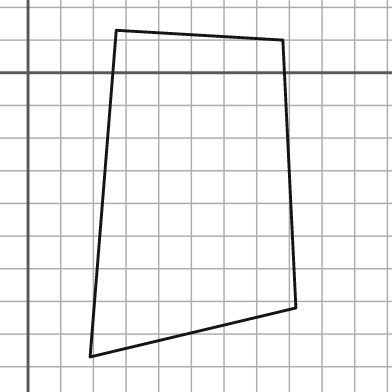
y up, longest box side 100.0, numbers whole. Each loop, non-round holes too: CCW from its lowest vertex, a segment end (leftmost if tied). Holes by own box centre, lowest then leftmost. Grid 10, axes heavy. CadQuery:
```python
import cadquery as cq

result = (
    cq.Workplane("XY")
    .moveTo(19.0, -87.0)
    .lineTo(82.0, -72.0)
    .lineTo(78.0, 10.0)
    .lineTo(27.0, 13.0)
    .close()
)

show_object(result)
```